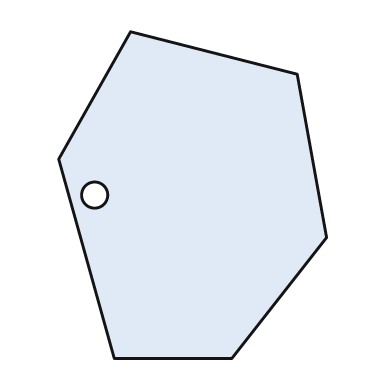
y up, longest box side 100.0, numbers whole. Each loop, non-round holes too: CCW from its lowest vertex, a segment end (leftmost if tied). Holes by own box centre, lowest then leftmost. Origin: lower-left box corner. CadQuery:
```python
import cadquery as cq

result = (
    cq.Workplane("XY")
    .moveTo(17.0, 0.0)
    .lineTo(53.0, 0.0)
    .lineTo(82.0, 37.0)
    .lineTo(73.0, 87.0)
    .lineTo(22.0, 100.0)
    .lineTo(0.0, 61.0)
    .close()
    .moveTo(11.0, 50.0)
    .circle(4.0)
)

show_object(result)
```